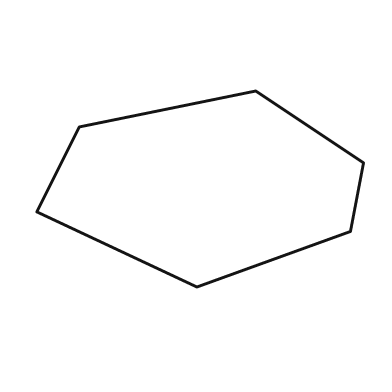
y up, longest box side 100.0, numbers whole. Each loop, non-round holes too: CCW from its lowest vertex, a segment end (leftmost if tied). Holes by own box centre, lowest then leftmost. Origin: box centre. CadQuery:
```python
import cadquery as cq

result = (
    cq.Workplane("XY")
    .moveTo(-1.0, -30.0)
    .lineTo(46.0, -13.0)
    .lineTo(50.0, 8.0)
    .lineTo(17.0, 30.0)
    .lineTo(-37.0, 19.0)
    .lineTo(-50.0, -7.0)
    .close()
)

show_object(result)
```